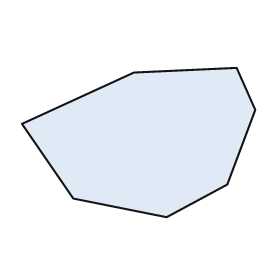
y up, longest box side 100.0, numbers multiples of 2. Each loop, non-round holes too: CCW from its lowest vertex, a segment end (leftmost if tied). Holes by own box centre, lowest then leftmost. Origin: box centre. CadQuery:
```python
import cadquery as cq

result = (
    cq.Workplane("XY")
    .moveTo(12.0, -32.0)
    .lineTo(38.0, -18.0)
    .lineTo(50.0, 14.0)
    .lineTo(42.0, 32.0)
    .lineTo(-2.0, 30.0)
    .lineTo(-50.0, 8.0)
    .lineTo(-28.0, -24.0)
    .close()
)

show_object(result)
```